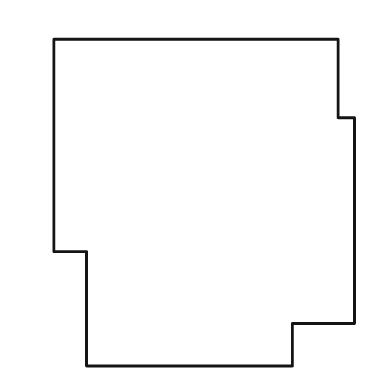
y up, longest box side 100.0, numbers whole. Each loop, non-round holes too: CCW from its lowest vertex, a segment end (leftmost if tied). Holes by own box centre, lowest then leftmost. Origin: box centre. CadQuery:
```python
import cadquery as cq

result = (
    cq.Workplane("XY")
    .moveTo(-36.0, -50.0)
    .lineTo(27.0, -50.0)
    .lineTo(27.0, -37.0)
    .lineTo(46.0, -37.0)
    .lineTo(46.0, 26.0)
    .lineTo(41.0, 26.0)
    .lineTo(41.0, 50.0)
    .lineTo(-46.0, 50.0)
    .lineTo(-46.0, -15.0)
    .lineTo(-36.0, -15.0)
    .close()
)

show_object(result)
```